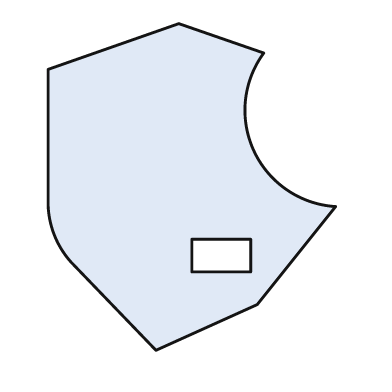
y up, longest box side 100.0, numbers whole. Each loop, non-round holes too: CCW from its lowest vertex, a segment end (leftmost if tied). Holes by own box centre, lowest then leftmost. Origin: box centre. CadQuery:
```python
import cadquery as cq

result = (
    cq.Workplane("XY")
    .moveTo(-11.0, -50.0)
    .lineTo(20.0, -36.0)
    .lineTo(44.0, -6.0)
    .threePointArc((19.0, 11.0), (22.0, 41.0))
    .lineTo(-4.0, 50.0)
    .lineTo(-44.0, 36.0)
    .lineTo(-44.0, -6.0)
    .threePointArc((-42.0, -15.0), (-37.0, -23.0))
    .close()
    .moveTo(0.0, -26.0)
    .lineTo(18.0, -26.0)
    .lineTo(18.0, -16.0)
    .lineTo(0.0, -16.0)
    .close()
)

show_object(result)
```